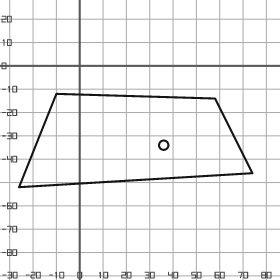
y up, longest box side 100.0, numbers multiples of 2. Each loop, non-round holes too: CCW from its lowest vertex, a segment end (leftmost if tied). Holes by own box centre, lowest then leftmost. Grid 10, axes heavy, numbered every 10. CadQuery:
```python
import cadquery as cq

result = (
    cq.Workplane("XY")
    .moveTo(-26.0, -52.0)
    .lineTo(74.0, -46.0)
    .lineTo(58.0, -14.0)
    .lineTo(-10.0, -12.0)
    .close()
    .moveTo(36.0, -34.0)
    .circle(2.0)
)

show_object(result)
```